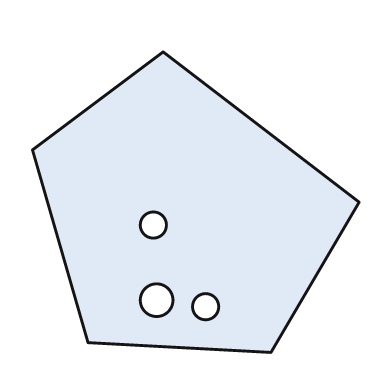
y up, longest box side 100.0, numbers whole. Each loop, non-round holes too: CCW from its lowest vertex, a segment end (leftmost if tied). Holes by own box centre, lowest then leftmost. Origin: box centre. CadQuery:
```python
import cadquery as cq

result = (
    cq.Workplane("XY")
    .moveTo(23.0, -46.0)
    .lineTo(50.0, 0.0)
    .lineTo(-10.0, 46.0)
    .lineTo(-50.0, 16.0)
    .lineTo(-33.0, -43.0)
    .close()
    .moveTo(3.0, -32.0)
    .circle(4.0)
    .moveTo(-12.0, -30.0)
    .circle(5.0)
    .moveTo(-13.0, -7.0)
    .circle(4.0)
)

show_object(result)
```